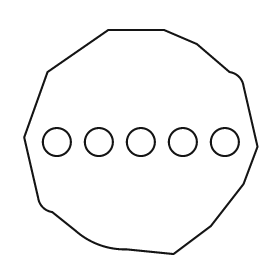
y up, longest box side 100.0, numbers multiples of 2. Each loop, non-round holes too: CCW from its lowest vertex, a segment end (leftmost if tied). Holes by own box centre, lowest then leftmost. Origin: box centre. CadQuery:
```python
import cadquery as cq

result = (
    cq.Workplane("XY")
    .moveTo(14.0, -48.0)
    .lineTo(30.0, -36.0)
    .lineTo(44.0, -18.0)
    .lineTo(50.0, -2.0)
    .lineTo(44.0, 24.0)
    .threePointArc((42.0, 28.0), (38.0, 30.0))
    .lineTo(24.0, 42.0)
    .lineTo(10.0, 48.0)
    .lineTo(-14.0, 48.0)
    .lineTo(-40.0, 30.0)
    .lineTo(-50.0, 2.0)
    .lineTo(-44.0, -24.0)
    .threePointArc((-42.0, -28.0), (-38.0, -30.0))
    .lineTo(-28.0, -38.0)
    .threePointArc((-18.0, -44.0), (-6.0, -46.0))
    .close()
    .moveTo(-36.0, 0.0)
    .circle(6.0)
    .moveTo(-18.0, 0.0)
    .circle(6.0)
    .moveTo(0.0, 0.0)
    .circle(6.0)
    .moveTo(18.0, 0.0)
    .circle(6.0)
    .moveTo(36.0, 0.0)
    .circle(6.0)
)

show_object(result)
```